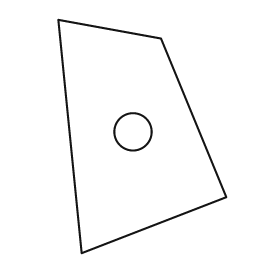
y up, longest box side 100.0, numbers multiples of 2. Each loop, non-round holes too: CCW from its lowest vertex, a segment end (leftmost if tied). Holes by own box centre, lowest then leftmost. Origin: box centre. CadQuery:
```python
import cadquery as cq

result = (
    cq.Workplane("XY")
    .moveTo(-26.0, -50.0)
    .lineTo(36.0, -26.0)
    .lineTo(8.0, 42.0)
    .lineTo(-36.0, 50.0)
    .close()
    .moveTo(-4.0, 2.0)
    .circle(8.0)
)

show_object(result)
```